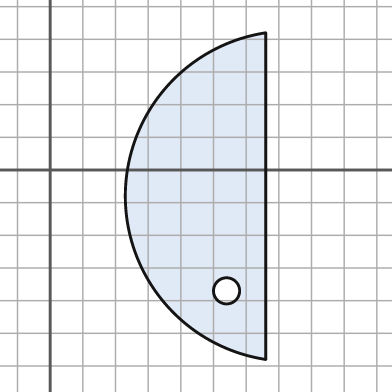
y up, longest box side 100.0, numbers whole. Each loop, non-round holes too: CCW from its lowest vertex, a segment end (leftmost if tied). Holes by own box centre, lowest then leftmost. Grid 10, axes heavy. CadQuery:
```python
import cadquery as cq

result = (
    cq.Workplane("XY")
    .moveTo(66.0, -58.0)
    .lineTo(66.0, 42.0)
    .threePointArc((23.0, -8.0), (66.0, -58.0))
    .close()
    .moveTo(54.0, -37.0)
    .circle(4.0)
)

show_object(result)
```